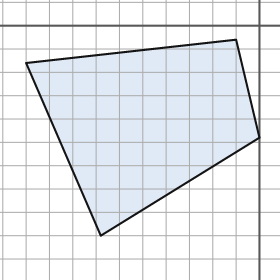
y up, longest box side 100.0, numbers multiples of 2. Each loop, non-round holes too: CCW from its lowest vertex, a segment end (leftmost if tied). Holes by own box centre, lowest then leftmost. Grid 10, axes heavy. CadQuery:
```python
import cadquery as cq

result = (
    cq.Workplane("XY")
    .moveTo(-68.0, -90.0)
    .lineTo(0.0, -48.0)
    .lineTo(-10.0, -6.0)
    .lineTo(-100.0, -16.0)
    .close()
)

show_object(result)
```